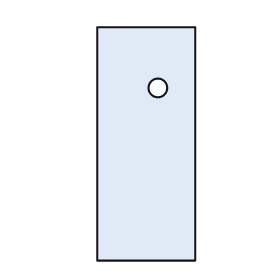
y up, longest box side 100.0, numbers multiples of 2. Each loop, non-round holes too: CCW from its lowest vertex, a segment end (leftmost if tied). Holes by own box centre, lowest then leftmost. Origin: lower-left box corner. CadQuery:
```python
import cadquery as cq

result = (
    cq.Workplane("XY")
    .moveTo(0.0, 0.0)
    .lineTo(42.0, 0.0)
    .lineTo(42.0, 100.0)
    .lineTo(0.0, 100.0)
    .close()
    .moveTo(26.0, 74.0)
    .circle(4.0)
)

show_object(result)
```